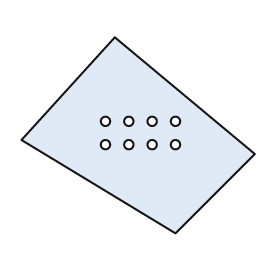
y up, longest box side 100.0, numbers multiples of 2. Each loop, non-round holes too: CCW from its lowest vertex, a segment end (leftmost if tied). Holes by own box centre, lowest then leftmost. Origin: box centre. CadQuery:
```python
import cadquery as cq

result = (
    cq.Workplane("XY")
    .moveTo(16.0, -42.0)
    .lineTo(50.0, -8.0)
    .lineTo(-10.0, 42.0)
    .lineTo(-50.0, -2.0)
    .close()
    .moveTo(-14.0, -4.0)
    .circle(2.0)
    .moveTo(-4.0, -4.0)
    .circle(2.0)
    .moveTo(6.0, -4.0)
    .circle(2.0)
    .moveTo(16.0, -4.0)
    .circle(2.0)
    .moveTo(-14.0, 6.0)
    .circle(2.0)
    .moveTo(-4.0, 6.0)
    .circle(2.0)
    .moveTo(6.0, 6.0)
    .circle(2.0)
    .moveTo(16.0, 6.0)
    .circle(2.0)
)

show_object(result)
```